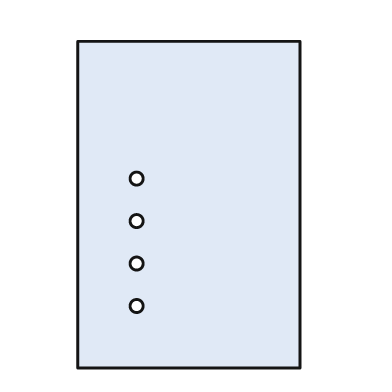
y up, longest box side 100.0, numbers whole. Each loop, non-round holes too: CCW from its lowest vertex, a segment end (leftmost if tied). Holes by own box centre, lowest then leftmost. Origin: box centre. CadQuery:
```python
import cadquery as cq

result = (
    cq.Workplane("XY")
    .moveTo(-34.0, -50.0)
    .lineTo(34.0, -50.0)
    .lineTo(34.0, 50.0)
    .lineTo(-34.0, 50.0)
    .close()
    .moveTo(-16.0, -31.0)
    .circle(2.0)
    .moveTo(-16.0, -18.0)
    .circle(2.0)
    .moveTo(-16.0, -5.0)
    .circle(2.0)
    .moveTo(-16.0, 8.0)
    .circle(2.0)
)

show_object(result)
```